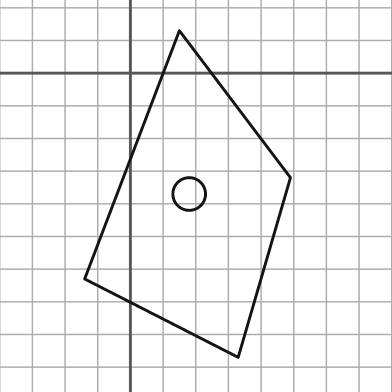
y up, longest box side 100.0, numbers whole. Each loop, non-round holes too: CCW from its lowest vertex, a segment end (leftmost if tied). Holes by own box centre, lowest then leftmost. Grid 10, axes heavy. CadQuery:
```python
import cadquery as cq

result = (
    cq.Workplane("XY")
    .moveTo(33.0, -87.0)
    .lineTo(49.0, -32.0)
    .lineTo(15.0, 13.0)
    .lineTo(-14.0, -63.0)
    .close()
    .moveTo(18.0, -37.0)
    .circle(5.0)
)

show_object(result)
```